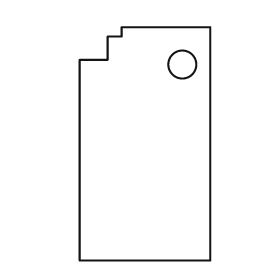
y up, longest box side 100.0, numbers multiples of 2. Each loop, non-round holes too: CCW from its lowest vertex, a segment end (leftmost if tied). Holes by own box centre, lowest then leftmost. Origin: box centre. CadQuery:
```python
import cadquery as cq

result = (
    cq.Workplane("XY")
    .moveTo(-28.0, -50.0)
    .lineTo(28.0, -50.0)
    .lineTo(28.0, 50.0)
    .lineTo(-10.0, 50.0)
    .lineTo(-10.0, 46.0)
    .lineTo(-16.0, 46.0)
    .lineTo(-16.0, 36.0)
    .lineTo(-28.0, 36.0)
    .close()
    .moveTo(16.0, 34.0)
    .circle(6.0)
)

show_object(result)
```